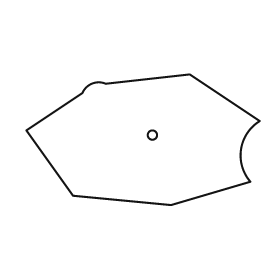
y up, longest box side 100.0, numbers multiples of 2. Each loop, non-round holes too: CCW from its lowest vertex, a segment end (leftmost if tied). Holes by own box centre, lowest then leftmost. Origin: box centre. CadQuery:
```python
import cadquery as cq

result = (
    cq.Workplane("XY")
    .moveTo(12.0, -28.0)
    .lineTo(46.0, -18.0)
    .threePointArc((42.0, -4.0), (50.0, 8.0))
    .lineTo(20.0, 28.0)
    .lineTo(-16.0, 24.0)
    .threePointArc((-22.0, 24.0), (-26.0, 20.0))
    .lineTo(-50.0, 4.0)
    .lineTo(-30.0, -24.0)
    .close()
    .moveTo(4.0, 2.0)
    .circle(2.0)
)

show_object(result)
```